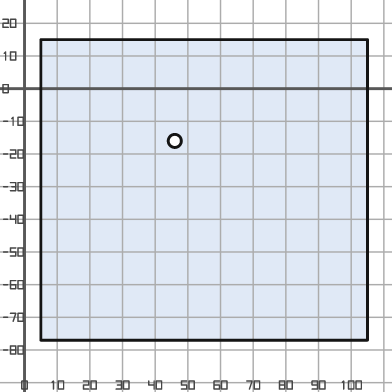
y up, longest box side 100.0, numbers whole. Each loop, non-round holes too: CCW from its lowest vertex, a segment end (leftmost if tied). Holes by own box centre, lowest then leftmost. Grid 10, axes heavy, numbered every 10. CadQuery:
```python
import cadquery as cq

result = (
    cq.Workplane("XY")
    .moveTo(5.0, -77.0)
    .lineTo(105.0, -77.0)
    .lineTo(105.0, 15.0)
    .lineTo(5.0, 15.0)
    .close()
    .moveTo(46.0, -16.0)
    .circle(2.0)
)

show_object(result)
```